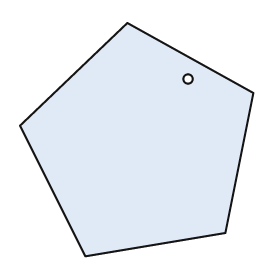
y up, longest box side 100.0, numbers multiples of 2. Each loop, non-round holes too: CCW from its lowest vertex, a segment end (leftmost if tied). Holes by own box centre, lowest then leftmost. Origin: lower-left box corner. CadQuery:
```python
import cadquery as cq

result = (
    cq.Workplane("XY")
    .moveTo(28.0, 0.0)
    .lineTo(88.0, 10.0)
    .lineTo(100.0, 70.0)
    .lineTo(46.0, 100.0)
    .lineTo(0.0, 56.0)
    .close()
    .moveTo(72.0, 76.0)
    .circle(2.0)
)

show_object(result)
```